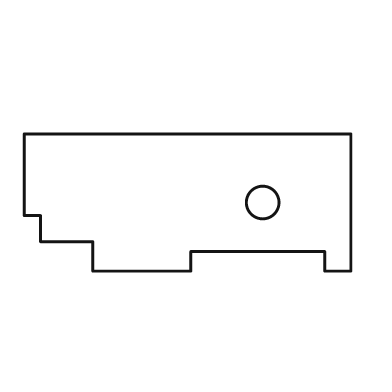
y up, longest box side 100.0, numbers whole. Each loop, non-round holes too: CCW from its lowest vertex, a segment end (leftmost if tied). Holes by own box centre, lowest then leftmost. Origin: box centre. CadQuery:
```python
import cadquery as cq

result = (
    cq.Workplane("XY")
    .moveTo(-29.0, -21.0)
    .lineTo(1.0, -21.0)
    .lineTo(1.0, -15.0)
    .lineTo(42.0, -15.0)
    .lineTo(42.0, -21.0)
    .lineTo(50.0, -21.0)
    .lineTo(50.0, 21.0)
    .lineTo(-50.0, 21.0)
    .lineTo(-50.0, -4.0)
    .lineTo(-45.0, -4.0)
    .lineTo(-45.0, -12.0)
    .lineTo(-29.0, -12.0)
    .close()
    .moveTo(23.0, 0.0)
    .circle(5.0)
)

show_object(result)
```